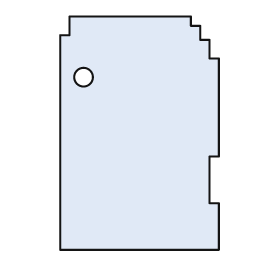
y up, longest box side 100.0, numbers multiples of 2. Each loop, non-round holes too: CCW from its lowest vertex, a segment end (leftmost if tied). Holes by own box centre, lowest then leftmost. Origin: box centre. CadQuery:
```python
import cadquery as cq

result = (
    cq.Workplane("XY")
    .moveTo(-34.0, -50.0)
    .lineTo(34.0, -50.0)
    .lineTo(34.0, -30.0)
    .lineTo(30.0, -30.0)
    .lineTo(30.0, -10.0)
    .lineTo(34.0, -10.0)
    .lineTo(34.0, 32.0)
    .lineTo(30.0, 32.0)
    .lineTo(30.0, 40.0)
    .lineTo(26.0, 40.0)
    .lineTo(26.0, 46.0)
    .lineTo(22.0, 46.0)
    .lineTo(22.0, 50.0)
    .lineTo(-30.0, 50.0)
    .lineTo(-30.0, 42.0)
    .lineTo(-34.0, 42.0)
    .close()
    .moveTo(-24.0, 24.0)
    .circle(4.0)
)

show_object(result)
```